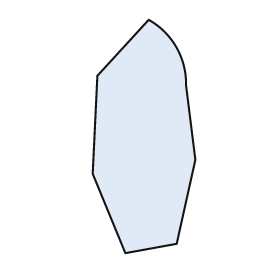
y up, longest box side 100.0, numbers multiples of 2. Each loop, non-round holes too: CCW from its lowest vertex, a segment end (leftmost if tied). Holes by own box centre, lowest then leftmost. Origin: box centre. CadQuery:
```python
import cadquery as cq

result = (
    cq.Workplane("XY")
    .moveTo(-8.0, -50.0)
    .lineTo(14.0, -46.0)
    .lineTo(22.0, -10.0)
    .lineTo(18.0, 22.0)
    .threePointArc((14.0, 38.0), (2.0, 50.0))
    .lineTo(-20.0, 26.0)
    .lineTo(-22.0, -16.0)
    .close()
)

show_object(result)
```